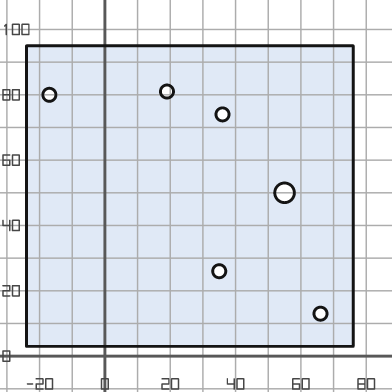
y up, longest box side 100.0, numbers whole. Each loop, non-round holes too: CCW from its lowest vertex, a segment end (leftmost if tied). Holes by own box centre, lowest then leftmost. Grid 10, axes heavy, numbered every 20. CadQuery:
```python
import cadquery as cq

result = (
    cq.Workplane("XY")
    .moveTo(-24.0, 3.0)
    .lineTo(76.0, 3.0)
    .lineTo(76.0, 95.0)
    .lineTo(-24.0, 95.0)
    .close()
    .moveTo(66.0, 13.0)
    .circle(2.0)
    .moveTo(35.0, 26.0)
    .circle(2.0)
    .moveTo(55.0, 50.0)
    .circle(3.0)
    .moveTo(36.0, 74.0)
    .circle(2.0)
    .moveTo(-17.0, 80.0)
    .circle(2.0)
    .moveTo(19.0, 81.0)
    .circle(2.0)
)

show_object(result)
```